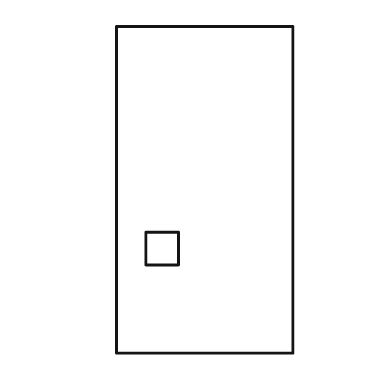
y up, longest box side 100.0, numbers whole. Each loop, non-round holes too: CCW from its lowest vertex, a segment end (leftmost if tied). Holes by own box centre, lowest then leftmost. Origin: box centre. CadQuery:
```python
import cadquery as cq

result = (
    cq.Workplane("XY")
    .moveTo(-27.0, -50.0)
    .lineTo(27.0, -50.0)
    .lineTo(27.0, 50.0)
    .lineTo(-27.0, 50.0)
    .close()
    .moveTo(-18.0, -23.0)
    .lineTo(-8.0, -23.0)
    .lineTo(-8.0, -13.0)
    .lineTo(-18.0, -13.0)
    .close()
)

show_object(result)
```